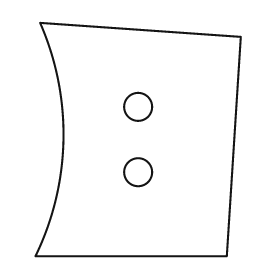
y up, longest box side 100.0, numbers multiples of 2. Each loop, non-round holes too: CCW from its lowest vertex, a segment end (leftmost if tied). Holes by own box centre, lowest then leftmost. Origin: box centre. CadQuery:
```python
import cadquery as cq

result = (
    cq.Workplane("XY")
    .moveTo(-44.0, -50.0)
    .lineTo(38.0, -50.0)
    .lineTo(44.0, 44.0)
    .lineTo(-42.0, 50.0)
    .threePointArc((-32.0, 0.0), (-44.0, -50.0))
    .close()
    .moveTo(0.0, -14.0)
    .circle(6.0)
    .moveTo(0.0, 14.0)
    .circle(6.0)
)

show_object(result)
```